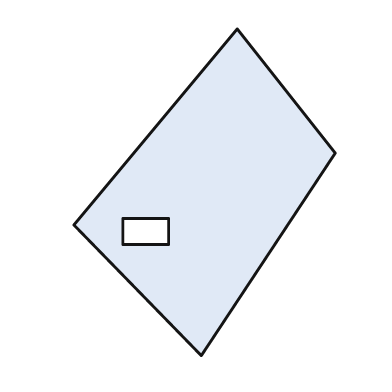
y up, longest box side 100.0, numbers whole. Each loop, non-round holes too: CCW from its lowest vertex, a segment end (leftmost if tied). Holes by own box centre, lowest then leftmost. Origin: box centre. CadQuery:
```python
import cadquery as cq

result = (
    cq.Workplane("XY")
    .moveTo(-1.0, -50.0)
    .lineTo(40.0, 12.0)
    .lineTo(10.0, 50.0)
    .lineTo(-40.0, -10.0)
    .close()
    .moveTo(-25.0, -16.0)
    .lineTo(-11.0, -16.0)
    .lineTo(-11.0, -8.0)
    .lineTo(-25.0, -8.0)
    .close()
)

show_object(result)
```